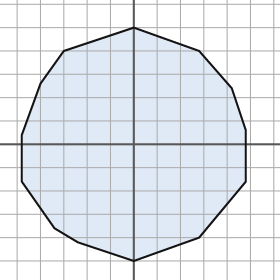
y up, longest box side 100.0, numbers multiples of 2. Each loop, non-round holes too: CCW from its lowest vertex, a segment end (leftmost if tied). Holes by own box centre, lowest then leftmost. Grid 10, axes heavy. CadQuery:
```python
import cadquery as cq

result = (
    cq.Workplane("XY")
    .moveTo(0.0, -50.0)
    .lineTo(28.0, -40.0)
    .lineTo(48.0, -16.0)
    .lineTo(48.0, 6.0)
    .lineTo(42.0, 24.0)
    .lineTo(28.0, 40.0)
    .lineTo(0.0, 50.0)
    .lineTo(-30.0, 40.0)
    .lineTo(-40.0, 26.0)
    .lineTo(-48.0, 4.0)
    .lineTo(-48.0, -16.0)
    .lineTo(-34.0, -36.0)
    .lineTo(-24.0, -42.0)
    .close()
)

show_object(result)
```